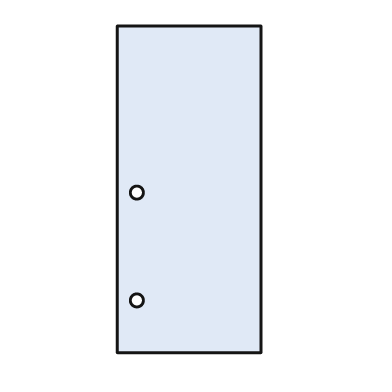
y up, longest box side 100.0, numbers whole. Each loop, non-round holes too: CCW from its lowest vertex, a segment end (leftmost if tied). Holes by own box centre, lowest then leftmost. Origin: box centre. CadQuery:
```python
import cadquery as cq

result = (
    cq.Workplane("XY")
    .moveTo(-22.0, -50.0)
    .lineTo(22.0, -50.0)
    .lineTo(22.0, 50.0)
    .lineTo(-22.0, 50.0)
    .close()
    .moveTo(-16.0, -34.0)
    .circle(2.0)
    .moveTo(-16.0, -1.0)
    .circle(2.0)
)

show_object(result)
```